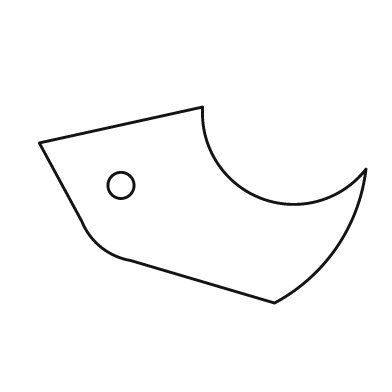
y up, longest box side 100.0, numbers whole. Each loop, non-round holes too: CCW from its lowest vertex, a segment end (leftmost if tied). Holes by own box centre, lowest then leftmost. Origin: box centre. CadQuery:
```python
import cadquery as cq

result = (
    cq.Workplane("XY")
    .moveTo(22.0, -30.0)
    .threePointArc((41.0, -13.0), (50.0, 11.0))
    .threePointArc((18.0, 2.0), (0.0, 30.0))
    .lineTo(-50.0, 19.0)
    .lineTo(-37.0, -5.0)
    .threePointArc((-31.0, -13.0), (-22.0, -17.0))
    .close()
    .moveTo(-25.0, 6.0)
    .circle(4.0)
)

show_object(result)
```